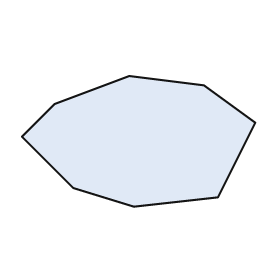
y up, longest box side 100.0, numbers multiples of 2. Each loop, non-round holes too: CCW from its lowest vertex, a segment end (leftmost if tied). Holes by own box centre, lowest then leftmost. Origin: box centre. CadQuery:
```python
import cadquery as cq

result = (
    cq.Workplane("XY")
    .moveTo(-2.0, -28.0)
    .lineTo(34.0, -24.0)
    .lineTo(50.0, 8.0)
    .lineTo(28.0, 24.0)
    .lineTo(-4.0, 28.0)
    .lineTo(-36.0, 16.0)
    .lineTo(-50.0, 2.0)
    .lineTo(-28.0, -20.0)
    .close()
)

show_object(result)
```